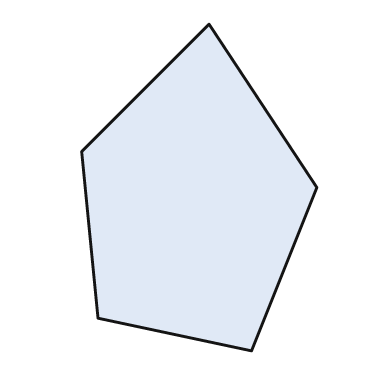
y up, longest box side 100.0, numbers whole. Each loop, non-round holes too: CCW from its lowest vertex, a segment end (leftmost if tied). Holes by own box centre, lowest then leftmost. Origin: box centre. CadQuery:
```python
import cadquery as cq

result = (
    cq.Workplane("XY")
    .moveTo(16.0, -50.0)
    .lineTo(36.0, 0.0)
    .lineTo(3.0, 50.0)
    .lineTo(-36.0, 11.0)
    .lineTo(-31.0, -40.0)
    .close()
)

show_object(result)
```